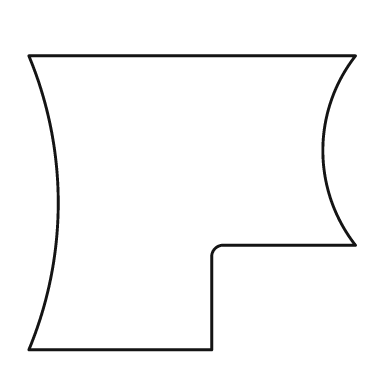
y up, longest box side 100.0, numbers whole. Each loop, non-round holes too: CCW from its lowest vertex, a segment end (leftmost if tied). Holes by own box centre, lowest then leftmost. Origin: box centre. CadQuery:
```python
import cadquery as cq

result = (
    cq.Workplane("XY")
    .moveTo(-50.0, -45.0)
    .lineTo(6.0, -45.0)
    .lineTo(6.0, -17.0)
    .threePointArc((7.0, -14.0), (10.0, -13.0))
    .lineTo(50.0, -13.0)
    .threePointArc((40.0, 16.0), (50.0, 45.0))
    .lineTo(-50.0, 45.0)
    .threePointArc((-41.0, 0.0), (-50.0, -45.0))
    .close()
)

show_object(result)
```